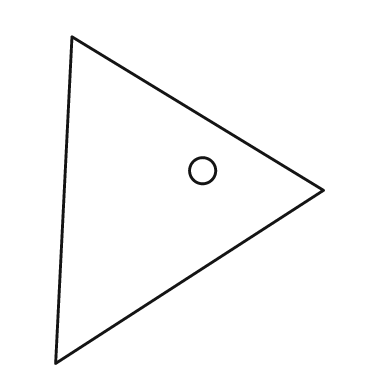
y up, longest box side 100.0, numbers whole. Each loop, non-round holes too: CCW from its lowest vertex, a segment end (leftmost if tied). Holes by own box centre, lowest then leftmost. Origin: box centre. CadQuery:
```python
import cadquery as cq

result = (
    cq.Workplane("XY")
    .moveTo(-41.0, -50.0)
    .lineTo(41.0, 3.0)
    .lineTo(-36.0, 50.0)
    .close()
    .moveTo(4.0, 9.0)
    .circle(4.0)
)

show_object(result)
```